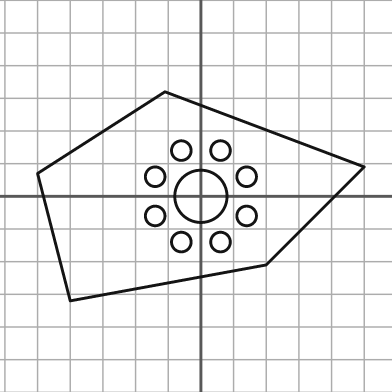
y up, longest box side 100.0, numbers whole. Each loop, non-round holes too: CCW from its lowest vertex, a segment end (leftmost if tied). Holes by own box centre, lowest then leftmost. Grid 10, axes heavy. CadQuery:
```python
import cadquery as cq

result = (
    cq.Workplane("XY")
    .moveTo(-40.0, -32.0)
    .lineTo(20.0, -21.0)
    .lineTo(50.0, 9.0)
    .lineTo(-11.0, 32.0)
    .lineTo(-50.0, 7.0)
    .close()
    .moveTo(-6.0, -14.0)
    .circle(3.0)
    .moveTo(6.0, -14.0)
    .circle(3.0)
    .moveTo(-14.0, -6.0)
    .circle(3.0)
    .moveTo(14.0, -6.0)
    .circle(3.0)
    .moveTo(0.0, 0.0)
    .circle(8.0)
    .moveTo(-14.0, 6.0)
    .circle(3.0)
    .moveTo(14.0, 6.0)
    .circle(3.0)
    .moveTo(-6.0, 14.0)
    .circle(3.0)
    .moveTo(6.0, 14.0)
    .circle(3.0)
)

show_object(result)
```